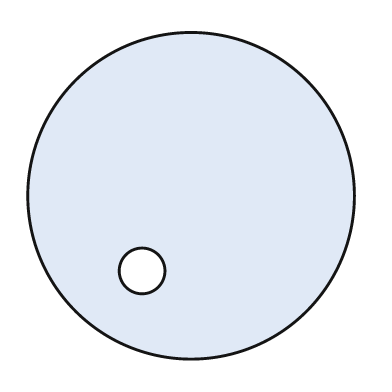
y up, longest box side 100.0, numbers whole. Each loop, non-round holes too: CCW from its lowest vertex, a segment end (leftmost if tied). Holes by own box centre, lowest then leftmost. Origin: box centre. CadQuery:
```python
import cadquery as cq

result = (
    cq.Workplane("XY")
    .moveTo(0.0, 0.0)
    .circle(50.0)
    .moveTo(-15.0, -23.0)
    .circle(7.0)
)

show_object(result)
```